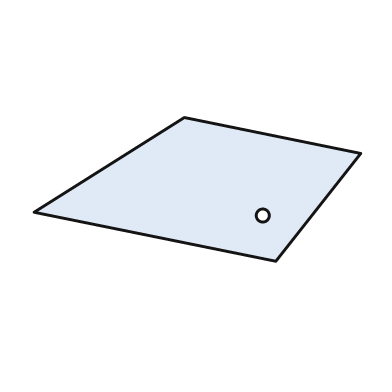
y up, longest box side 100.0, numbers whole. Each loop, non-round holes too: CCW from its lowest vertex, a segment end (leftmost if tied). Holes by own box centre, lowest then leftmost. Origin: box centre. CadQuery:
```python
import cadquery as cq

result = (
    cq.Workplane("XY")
    .moveTo(24.0, -22.0)
    .lineTo(50.0, 11.0)
    .lineTo(-4.0, 22.0)
    .lineTo(-50.0, -7.0)
    .close()
    .moveTo(20.0, -8.0)
    .circle(2.0)
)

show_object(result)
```